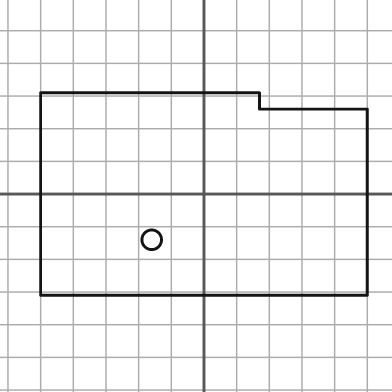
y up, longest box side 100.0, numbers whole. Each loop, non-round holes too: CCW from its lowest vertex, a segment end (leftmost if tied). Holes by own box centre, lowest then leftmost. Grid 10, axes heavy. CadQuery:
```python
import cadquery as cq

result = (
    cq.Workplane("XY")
    .moveTo(-50.0, -31.0)
    .lineTo(50.0, -31.0)
    .lineTo(50.0, 26.0)
    .lineTo(17.0, 26.0)
    .lineTo(17.0, 31.0)
    .lineTo(-50.0, 31.0)
    .close()
    .moveTo(-16.0, -14.0)
    .circle(3.0)
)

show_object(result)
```